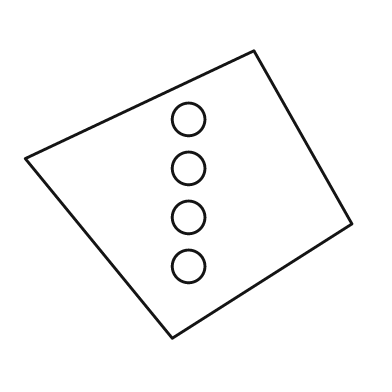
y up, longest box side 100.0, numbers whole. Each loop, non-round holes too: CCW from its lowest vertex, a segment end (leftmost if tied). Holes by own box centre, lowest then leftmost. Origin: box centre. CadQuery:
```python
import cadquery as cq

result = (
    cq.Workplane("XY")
    .moveTo(-5.0, -44.0)
    .lineTo(50.0, -9.0)
    .lineTo(20.0, 44.0)
    .lineTo(-50.0, 11.0)
    .close()
    .moveTo(0.0, -22.0)
    .circle(5.0)
    .moveTo(0.0, -7.0)
    .circle(5.0)
    .moveTo(0.0, 8.0)
    .circle(5.0)
    .moveTo(0.0, 23.0)
    .circle(5.0)
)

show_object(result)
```